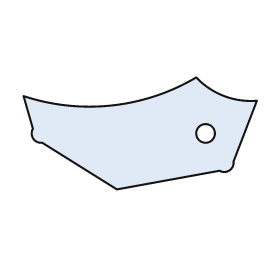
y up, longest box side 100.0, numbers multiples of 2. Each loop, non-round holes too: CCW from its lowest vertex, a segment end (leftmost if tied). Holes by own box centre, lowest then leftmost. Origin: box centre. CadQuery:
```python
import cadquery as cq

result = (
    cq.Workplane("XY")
    .moveTo(-10.0, -24.0)
    .lineTo(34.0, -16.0)
    .threePointArc((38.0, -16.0), (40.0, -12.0))
    .lineTo(50.0, 14.0)
    .threePointArc((36.0, 16.0), (24.0, 24.0))
    .threePointArc((-12.0, 12.0), (-50.0, 16.0))
    .lineTo(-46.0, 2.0)
    .threePointArc((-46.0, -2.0), (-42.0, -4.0))
    .close()
    .moveTo(28.0, 0.0)
    .circle(4.0)
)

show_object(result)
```